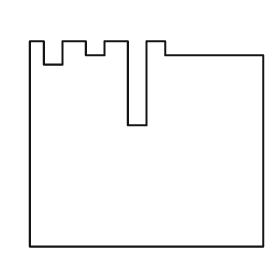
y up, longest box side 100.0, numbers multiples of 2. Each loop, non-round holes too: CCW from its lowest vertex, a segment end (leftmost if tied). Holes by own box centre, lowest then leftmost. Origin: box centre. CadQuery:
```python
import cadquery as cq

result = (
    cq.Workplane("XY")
    .moveTo(-50.0, -44.0)
    .lineTo(50.0, -44.0)
    .lineTo(50.0, 38.0)
    .lineTo(8.0, 38.0)
    .lineTo(8.0, 44.0)
    .lineTo(0.0, 44.0)
    .lineTo(0.0, 8.0)
    .lineTo(-8.0, 8.0)
    .lineTo(-8.0, 44.0)
    .lineTo(-18.0, 44.0)
    .lineTo(-18.0, 38.0)
    .lineTo(-26.0, 38.0)
    .lineTo(-26.0, 44.0)
    .lineTo(-36.0, 44.0)
    .lineTo(-36.0, 34.0)
    .lineTo(-44.0, 34.0)
    .lineTo(-44.0, 44.0)
    .lineTo(-50.0, 44.0)
    .close()
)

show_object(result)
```